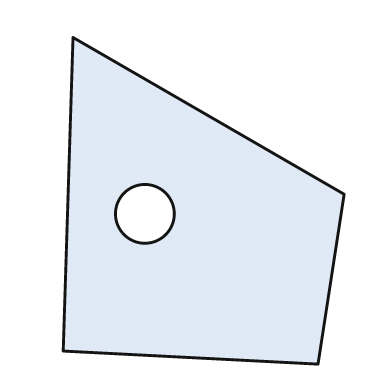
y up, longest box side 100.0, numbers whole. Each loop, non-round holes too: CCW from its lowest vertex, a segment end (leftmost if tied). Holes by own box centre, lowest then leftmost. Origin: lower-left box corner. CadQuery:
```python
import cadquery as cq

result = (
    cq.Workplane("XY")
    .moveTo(78.0, 0.0)
    .lineTo(86.0, 52.0)
    .lineTo(3.0, 100.0)
    .lineTo(0.0, 4.0)
    .close()
    .moveTo(25.0, 46.0)
    .circle(9.0)
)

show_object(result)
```